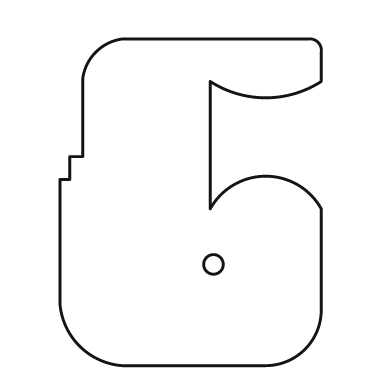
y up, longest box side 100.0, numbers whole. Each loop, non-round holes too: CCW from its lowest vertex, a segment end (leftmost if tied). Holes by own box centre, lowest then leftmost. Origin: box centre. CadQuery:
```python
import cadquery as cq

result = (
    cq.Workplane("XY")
    .moveTo(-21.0, -50.0)
    .lineTo(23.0, -50.0)
    .threePointArc((35.0, -45.0), (40.0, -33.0))
    .lineTo(40.0, -2.0)
    .threePointArc((23.0, 8.0), (6.0, -2.0))
    .lineTo(6.0, 37.0)
    .threePointArc((23.0, 32.0), (40.0, 37.0))
    .lineTo(40.0, 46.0)
    .threePointArc((39.0, 49.0), (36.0, 50.0))
    .lineTo(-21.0, 50.0)
    .threePointArc((-29.0, 46.0), (-33.0, 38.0))
    .lineTo(-33.0, 14.0)
    .lineTo(-37.0, 14.0)
    .lineTo(-37.0, 7.0)
    .lineTo(-40.0, 7.0)
    .lineTo(-40.0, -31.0)
    .threePointArc((-34.0, -44.0), (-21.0, -50.0))
    .close()
    .moveTo(7.0, -19.0)
    .circle(3.0)
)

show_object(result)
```